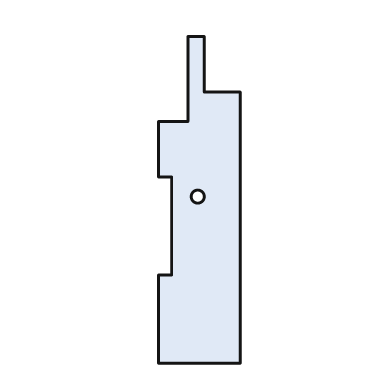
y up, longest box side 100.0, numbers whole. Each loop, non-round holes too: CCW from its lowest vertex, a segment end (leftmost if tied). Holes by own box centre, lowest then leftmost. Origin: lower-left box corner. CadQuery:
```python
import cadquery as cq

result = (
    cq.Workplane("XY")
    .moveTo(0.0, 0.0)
    .lineTo(25.0, 0.0)
    .lineTo(25.0, 83.0)
    .lineTo(14.0, 83.0)
    .lineTo(14.0, 100.0)
    .lineTo(9.0, 100.0)
    .lineTo(9.0, 74.0)
    .lineTo(0.0, 74.0)
    .lineTo(0.0, 57.0)
    .lineTo(4.0, 57.0)
    .lineTo(4.0, 27.0)
    .lineTo(0.0, 27.0)
    .close()
    .moveTo(12.0, 51.0)
    .circle(2.0)
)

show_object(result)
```